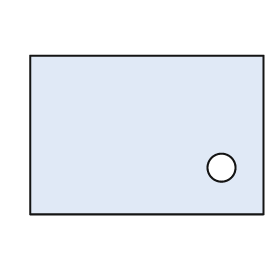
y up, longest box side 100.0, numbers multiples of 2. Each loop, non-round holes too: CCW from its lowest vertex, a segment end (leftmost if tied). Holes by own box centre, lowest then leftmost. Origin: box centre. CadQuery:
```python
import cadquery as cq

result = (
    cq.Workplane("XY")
    .moveTo(-50.0, -34.0)
    .lineTo(50.0, -34.0)
    .lineTo(50.0, 34.0)
    .lineTo(-50.0, 34.0)
    .close()
    .moveTo(32.0, -14.0)
    .circle(6.0)
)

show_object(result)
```